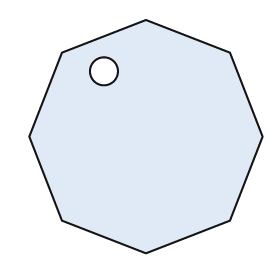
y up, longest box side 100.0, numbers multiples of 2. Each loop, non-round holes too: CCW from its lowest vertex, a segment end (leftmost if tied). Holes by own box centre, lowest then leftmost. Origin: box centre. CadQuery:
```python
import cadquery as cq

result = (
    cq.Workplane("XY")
    .moveTo(0.0, -50.0)
    .lineTo(36.0, -36.0)
    .lineTo(50.0, 0.0)
    .lineTo(36.0, 36.0)
    .lineTo(0.0, 50.0)
    .lineTo(-36.0, 36.0)
    .lineTo(-50.0, 0.0)
    .lineTo(-36.0, -36.0)
    .close()
    .moveTo(-18.0, 28.0)
    .circle(6.0)
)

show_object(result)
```